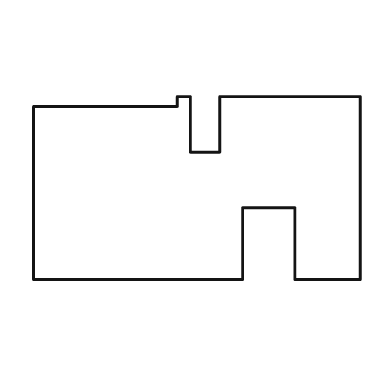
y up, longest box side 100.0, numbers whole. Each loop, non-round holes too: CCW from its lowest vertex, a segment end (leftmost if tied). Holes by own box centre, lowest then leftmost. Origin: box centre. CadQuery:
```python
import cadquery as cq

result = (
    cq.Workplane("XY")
    .moveTo(-50.0, -28.0)
    .lineTo(14.0, -28.0)
    .lineTo(14.0, -6.0)
    .lineTo(30.0, -6.0)
    .lineTo(30.0, -28.0)
    .lineTo(50.0, -28.0)
    .lineTo(50.0, 28.0)
    .lineTo(7.0, 28.0)
    .lineTo(7.0, 11.0)
    .lineTo(-2.0, 11.0)
    .lineTo(-2.0, 28.0)
    .lineTo(-6.0, 28.0)
    .lineTo(-6.0, 25.0)
    .lineTo(-50.0, 25.0)
    .close()
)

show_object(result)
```